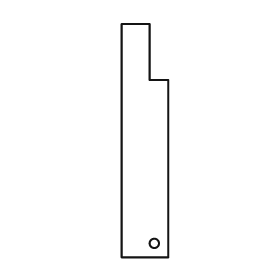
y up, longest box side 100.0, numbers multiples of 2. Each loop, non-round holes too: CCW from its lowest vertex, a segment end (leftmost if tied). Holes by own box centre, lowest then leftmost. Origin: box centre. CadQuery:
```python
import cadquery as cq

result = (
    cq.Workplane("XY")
    .moveTo(-10.0, -50.0)
    .lineTo(10.0, -50.0)
    .lineTo(10.0, 26.0)
    .lineTo(2.0, 26.0)
    .lineTo(2.0, 50.0)
    .lineTo(-10.0, 50.0)
    .close()
    .moveTo(4.0, -44.0)
    .circle(2.0)
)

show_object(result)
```